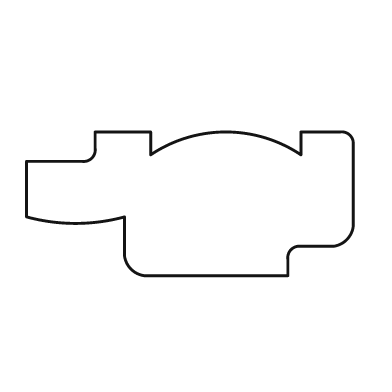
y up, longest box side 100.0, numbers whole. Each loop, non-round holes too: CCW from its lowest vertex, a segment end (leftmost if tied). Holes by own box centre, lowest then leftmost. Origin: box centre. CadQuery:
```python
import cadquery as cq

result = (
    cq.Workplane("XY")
    .moveTo(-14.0, -22.0)
    .lineTo(30.0, -22.0)
    .lineTo(30.0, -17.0)
    .threePointArc((31.0, -14.0), (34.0, -13.0))
    .lineTo(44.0, -13.0)
    .threePointArc((48.0, -11.0), (50.0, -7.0))
    .lineTo(50.0, 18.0)
    .threePointArc((49.0, 21.0), (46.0, 22.0))
    .lineTo(34.0, 22.0)
    .lineTo(34.0, 15.0)
    .threePointArc((11.0, 22.0), (-12.0, 15.0))
    .lineTo(-12.0, 22.0)
    .lineTo(-29.0, 22.0)
    .lineTo(-29.0, 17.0)
    .threePointArc((-30.0, 14.0), (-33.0, 13.0))
    .lineTo(-50.0, 13.0)
    .lineTo(-50.0, -4.0)
    .threePointArc((-35.0, -6.0), (-20.0, -4.0))
    .lineTo(-20.0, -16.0)
    .threePointArc((-18.0, -20.0), (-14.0, -22.0))
    .close()
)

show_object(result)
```